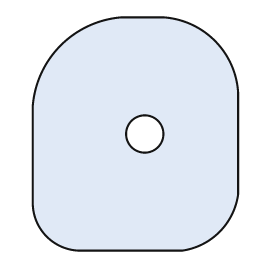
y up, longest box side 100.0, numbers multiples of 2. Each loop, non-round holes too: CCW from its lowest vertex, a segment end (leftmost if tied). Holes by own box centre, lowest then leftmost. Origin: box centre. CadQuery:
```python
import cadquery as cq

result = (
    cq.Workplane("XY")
    .moveTo(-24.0, -50.0)
    .lineTo(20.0, -50.0)
    .threePointArc((36.0, -42.0), (44.0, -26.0))
    .lineTo(44.0, 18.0)
    .threePointArc((34.0, 40.0), (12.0, 50.0))
    .lineTo(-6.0, 50.0)
    .threePointArc((-32.0, 38.0), (-44.0, 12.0))
    .lineTo(-44.0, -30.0)
    .threePointArc((-38.0, -44.0), (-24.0, -50.0))
    .close()
    .moveTo(4.0, 0.0)
    .circle(8.0)
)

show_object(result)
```